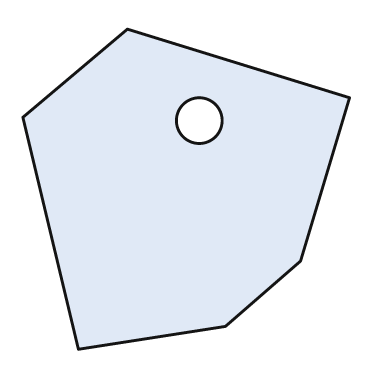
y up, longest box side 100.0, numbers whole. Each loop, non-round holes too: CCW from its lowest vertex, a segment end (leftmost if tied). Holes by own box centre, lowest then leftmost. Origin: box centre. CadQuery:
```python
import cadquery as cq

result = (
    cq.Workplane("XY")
    .moveTo(-33.0, -49.0)
    .lineTo(12.0, -42.0)
    .lineTo(35.0, -22.0)
    .lineTo(50.0, 28.0)
    .lineTo(-18.0, 49.0)
    .lineTo(-50.0, 22.0)
    .close()
    .moveTo(4.0, 21.0)
    .circle(7.0)
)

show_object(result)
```